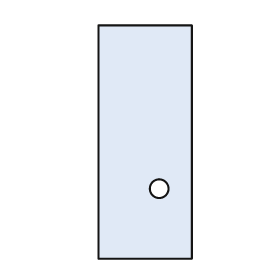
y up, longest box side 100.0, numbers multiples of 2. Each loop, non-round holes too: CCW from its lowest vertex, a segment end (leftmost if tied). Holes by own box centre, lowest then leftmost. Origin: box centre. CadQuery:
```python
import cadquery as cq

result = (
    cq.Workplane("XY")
    .moveTo(-20.0, -50.0)
    .lineTo(20.0, -50.0)
    .lineTo(20.0, 50.0)
    .lineTo(-20.0, 50.0)
    .close()
    .moveTo(6.0, -20.0)
    .circle(4.0)
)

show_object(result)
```